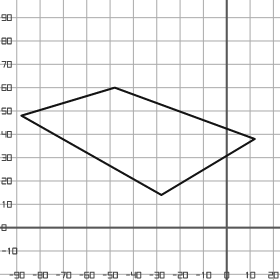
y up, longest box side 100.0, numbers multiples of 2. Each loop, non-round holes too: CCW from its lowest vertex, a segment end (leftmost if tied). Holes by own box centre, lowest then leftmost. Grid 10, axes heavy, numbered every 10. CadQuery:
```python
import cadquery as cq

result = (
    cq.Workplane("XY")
    .moveTo(-28.0, 14.0)
    .lineTo(12.0, 38.0)
    .lineTo(-48.0, 60.0)
    .lineTo(-88.0, 48.0)
    .close()
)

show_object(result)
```